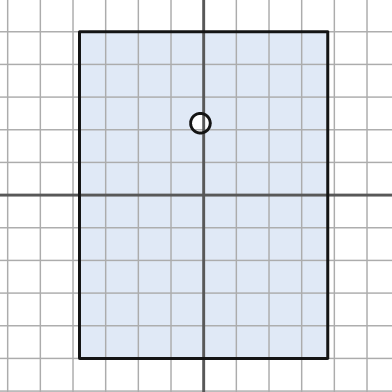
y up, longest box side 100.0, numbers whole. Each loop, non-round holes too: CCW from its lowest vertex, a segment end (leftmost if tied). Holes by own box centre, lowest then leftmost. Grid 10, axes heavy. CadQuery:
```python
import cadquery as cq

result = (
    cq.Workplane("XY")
    .moveTo(-38.0, -50.0)
    .lineTo(38.0, -50.0)
    .lineTo(38.0, 50.0)
    .lineTo(-38.0, 50.0)
    .close()
    .moveTo(-1.0, 22.0)
    .circle(3.0)
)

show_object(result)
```